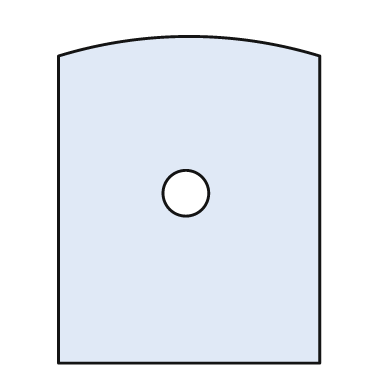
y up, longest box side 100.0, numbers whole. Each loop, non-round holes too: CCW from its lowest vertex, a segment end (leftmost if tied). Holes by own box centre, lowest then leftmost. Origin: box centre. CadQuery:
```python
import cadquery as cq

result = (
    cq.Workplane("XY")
    .moveTo(-40.0, -50.0)
    .lineTo(40.0, -50.0)
    .lineTo(40.0, 44.0)
    .threePointArc((0.0, 50.0), (-40.0, 44.0))
    .close()
    .moveTo(-1.0, 2.0)
    .circle(7.0)
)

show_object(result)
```